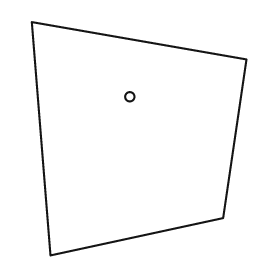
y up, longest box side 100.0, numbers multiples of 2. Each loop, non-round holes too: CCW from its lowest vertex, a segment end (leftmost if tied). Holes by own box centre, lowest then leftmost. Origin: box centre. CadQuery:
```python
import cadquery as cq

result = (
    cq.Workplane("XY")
    .moveTo(-38.0, -50.0)
    .lineTo(36.0, -34.0)
    .lineTo(46.0, 34.0)
    .lineTo(-46.0, 50.0)
    .close()
    .moveTo(-4.0, 18.0)
    .circle(2.0)
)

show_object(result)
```